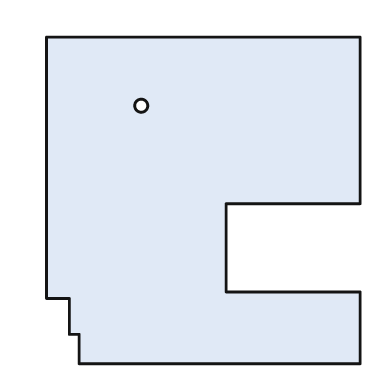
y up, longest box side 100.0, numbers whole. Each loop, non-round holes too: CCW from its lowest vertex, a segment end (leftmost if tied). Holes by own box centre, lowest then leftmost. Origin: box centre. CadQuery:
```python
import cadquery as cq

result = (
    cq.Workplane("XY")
    .moveTo(-38.0, -50.0)
    .lineTo(48.0, -50.0)
    .lineTo(48.0, -28.0)
    .lineTo(7.0, -28.0)
    .lineTo(7.0, -1.0)
    .lineTo(48.0, -1.0)
    .lineTo(48.0, 50.0)
    .lineTo(-48.0, 50.0)
    .lineTo(-48.0, -30.0)
    .lineTo(-41.0, -30.0)
    .lineTo(-41.0, -41.0)
    .lineTo(-38.0, -41.0)
    .close()
    .moveTo(-19.0, 29.0)
    .circle(2.0)
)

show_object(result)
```